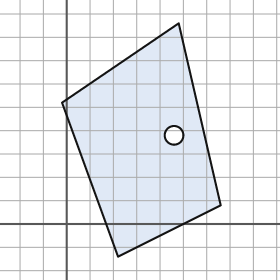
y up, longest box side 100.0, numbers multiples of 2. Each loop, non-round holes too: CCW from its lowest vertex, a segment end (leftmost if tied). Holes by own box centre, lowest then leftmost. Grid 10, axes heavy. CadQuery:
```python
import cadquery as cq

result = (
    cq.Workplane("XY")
    .moveTo(22.0, -14.0)
    .lineTo(66.0, 8.0)
    .lineTo(48.0, 86.0)
    .lineTo(-2.0, 52.0)
    .close()
    .moveTo(46.0, 38.0)
    .circle(4.0)
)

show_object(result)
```